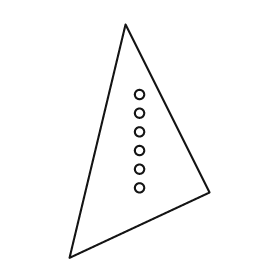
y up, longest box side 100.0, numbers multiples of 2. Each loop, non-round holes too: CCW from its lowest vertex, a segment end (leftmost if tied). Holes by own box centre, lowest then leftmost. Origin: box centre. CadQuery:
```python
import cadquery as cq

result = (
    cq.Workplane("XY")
    .moveTo(-30.0, -50.0)
    .lineTo(30.0, -22.0)
    .lineTo(-6.0, 50.0)
    .close()
    .moveTo(0.0, -20.0)
    .circle(2.0)
    .moveTo(0.0, -12.0)
    .circle(2.0)
    .moveTo(0.0, -4.0)
    .circle(2.0)
    .moveTo(0.0, 4.0)
    .circle(2.0)
    .moveTo(0.0, 12.0)
    .circle(2.0)
    .moveTo(0.0, 20.0)
    .circle(2.0)
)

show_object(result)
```